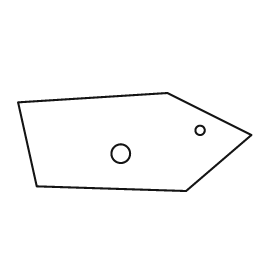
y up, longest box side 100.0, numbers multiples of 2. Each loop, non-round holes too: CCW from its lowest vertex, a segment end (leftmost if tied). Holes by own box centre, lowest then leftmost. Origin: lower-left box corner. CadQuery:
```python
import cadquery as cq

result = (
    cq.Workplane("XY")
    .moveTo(72.0, 0.0)
    .lineTo(100.0, 24.0)
    .lineTo(64.0, 42.0)
    .lineTo(0.0, 38.0)
    .lineTo(8.0, 2.0)
    .close()
    .moveTo(44.0, 16.0)
    .circle(4.0)
    .moveTo(78.0, 26.0)
    .circle(2.0)
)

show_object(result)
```